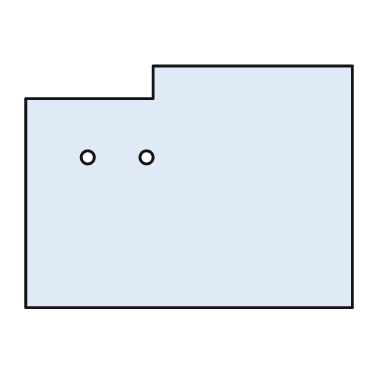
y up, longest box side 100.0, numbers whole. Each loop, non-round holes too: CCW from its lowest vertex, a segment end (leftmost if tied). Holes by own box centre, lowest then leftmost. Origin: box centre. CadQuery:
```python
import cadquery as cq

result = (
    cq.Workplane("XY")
    .moveTo(-50.0, -37.0)
    .lineTo(50.0, -37.0)
    .lineTo(50.0, 37.0)
    .lineTo(-11.0, 37.0)
    .lineTo(-11.0, 27.0)
    .lineTo(-50.0, 27.0)
    .close()
    .moveTo(-31.0, 9.0)
    .circle(2.0)
    .moveTo(-13.0, 9.0)
    .circle(2.0)
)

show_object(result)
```